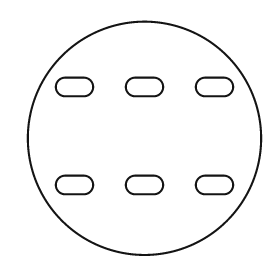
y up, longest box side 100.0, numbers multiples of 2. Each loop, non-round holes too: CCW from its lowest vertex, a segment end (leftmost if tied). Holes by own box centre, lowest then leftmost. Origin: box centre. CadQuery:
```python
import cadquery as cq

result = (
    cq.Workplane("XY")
    .moveTo(0.0, 0.0)
    .circle(50.0)
    .moveTo(-34.0, -24.0)
    .lineTo(-26.0, -24.0)
    .threePointArc((-22.0, -20.0), (-26.0, -16.0))
    .lineTo(-34.0, -16.0)
    .threePointArc((-38.0, -20.0), (-34.0, -24.0))
    .close()
    .moveTo(-4.0, -24.0)
    .lineTo(4.0, -24.0)
    .threePointArc((8.0, -20.0), (4.0, -16.0))
    .lineTo(-4.0, -16.0)
    .threePointArc((-8.0, -20.0), (-4.0, -24.0))
    .close()
    .moveTo(26.0, -24.0)
    .lineTo(34.0, -24.0)
    .threePointArc((38.0, -20.0), (34.0, -16.0))
    .lineTo(26.0, -16.0)
    .threePointArc((22.0, -20.0), (26.0, -24.0))
    .close()
    .moveTo(-34.0, 18.0)
    .lineTo(-26.0, 18.0)
    .threePointArc((-22.0, 22.0), (-26.0, 26.0))
    .lineTo(-34.0, 26.0)
    .threePointArc((-38.0, 22.0), (-34.0, 18.0))
    .close()
    .moveTo(-4.0, 18.0)
    .lineTo(4.0, 18.0)
    .threePointArc((8.0, 22.0), (4.0, 26.0))
    .lineTo(-4.0, 26.0)
    .threePointArc((-8.0, 22.0), (-4.0, 18.0))
    .close()
    .moveTo(26.0, 18.0)
    .lineTo(34.0, 18.0)
    .threePointArc((38.0, 22.0), (34.0, 26.0))
    .lineTo(26.0, 26.0)
    .threePointArc((22.0, 22.0), (26.0, 18.0))
    .close()
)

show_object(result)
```